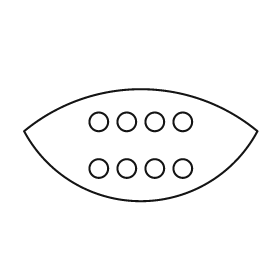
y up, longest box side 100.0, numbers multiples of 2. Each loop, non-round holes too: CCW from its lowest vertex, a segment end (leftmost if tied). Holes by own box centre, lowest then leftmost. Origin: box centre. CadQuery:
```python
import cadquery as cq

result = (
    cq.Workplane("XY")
    .moveTo(-50.0, 6.0)
    .threePointArc((0.0, -24.0), (50.0, 6.0))
    .threePointArc((0.0, 24.0), (-50.0, 6.0))
    .close()
    .moveTo(-18.0, -10.0)
    .circle(4.0)
    .moveTo(-6.0, -10.0)
    .circle(4.0)
    .moveTo(6.0, -10.0)
    .circle(4.0)
    .moveTo(18.0, -10.0)
    .circle(4.0)
    .moveTo(-18.0, 10.0)
    .circle(4.0)
    .moveTo(-6.0, 10.0)
    .circle(4.0)
    .moveTo(6.0, 10.0)
    .circle(4.0)
    .moveTo(18.0, 10.0)
    .circle(4.0)
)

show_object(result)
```